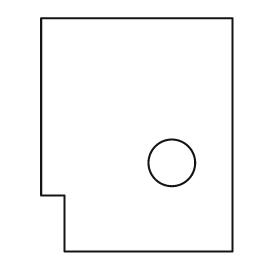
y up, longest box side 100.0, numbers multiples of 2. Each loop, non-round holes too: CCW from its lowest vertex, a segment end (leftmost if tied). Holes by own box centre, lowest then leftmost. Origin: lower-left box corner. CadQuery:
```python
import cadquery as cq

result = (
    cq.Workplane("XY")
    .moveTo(10.0, 0.0)
    .lineTo(82.0, 0.0)
    .lineTo(82.0, 100.0)
    .lineTo(0.0, 100.0)
    .lineTo(0.0, 24.0)
    .lineTo(10.0, 24.0)
    .close()
    .moveTo(56.0, 38.0)
    .circle(10.0)
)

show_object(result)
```